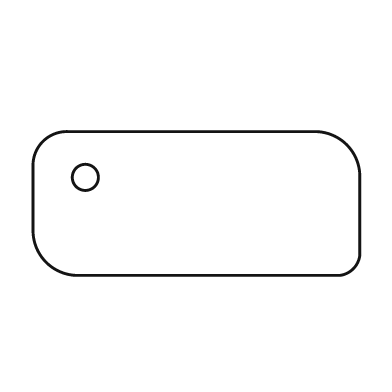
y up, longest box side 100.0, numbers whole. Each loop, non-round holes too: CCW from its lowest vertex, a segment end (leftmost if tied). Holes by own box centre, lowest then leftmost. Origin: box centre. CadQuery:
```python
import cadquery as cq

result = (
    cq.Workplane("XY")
    .moveTo(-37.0, -22.0)
    .lineTo(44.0, -22.0)
    .threePointArc((48.0, -20.0), (50.0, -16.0))
    .lineTo(50.0, 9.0)
    .threePointArc((46.0, 18.0), (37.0, 22.0))
    .lineTo(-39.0, 22.0)
    .threePointArc((-47.0, 19.0), (-50.0, 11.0))
    .lineTo(-50.0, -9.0)
    .threePointArc((-46.0, -18.0), (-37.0, -22.0))
    .close()
    .moveTo(-34.0, 8.0)
    .circle(4.0)
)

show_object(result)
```